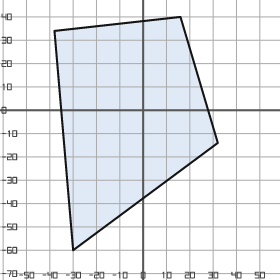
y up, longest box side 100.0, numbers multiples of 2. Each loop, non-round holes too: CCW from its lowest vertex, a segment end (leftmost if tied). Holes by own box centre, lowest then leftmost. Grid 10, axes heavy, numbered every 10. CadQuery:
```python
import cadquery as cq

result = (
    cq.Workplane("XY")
    .moveTo(-30.0, -60.0)
    .lineTo(32.0, -14.0)
    .lineTo(16.0, 40.0)
    .lineTo(-38.0, 34.0)
    .close()
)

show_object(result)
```